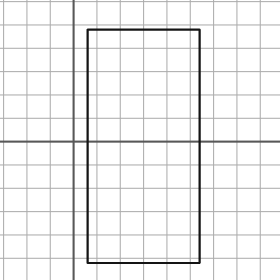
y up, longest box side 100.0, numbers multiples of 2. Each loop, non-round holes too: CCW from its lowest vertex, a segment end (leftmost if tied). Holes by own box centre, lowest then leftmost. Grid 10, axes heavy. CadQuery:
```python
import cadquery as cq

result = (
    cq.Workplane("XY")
    .moveTo(6.0, -52.0)
    .lineTo(54.0, -52.0)
    .lineTo(54.0, 48.0)
    .lineTo(6.0, 48.0)
    .close()
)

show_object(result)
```